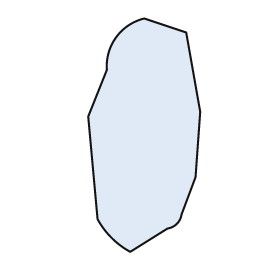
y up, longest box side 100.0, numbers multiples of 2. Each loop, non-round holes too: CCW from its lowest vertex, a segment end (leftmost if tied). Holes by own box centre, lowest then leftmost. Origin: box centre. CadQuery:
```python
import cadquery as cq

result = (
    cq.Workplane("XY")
    .moveTo(-6.0, -50.0)
    .lineTo(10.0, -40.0)
    .threePointArc((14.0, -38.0), (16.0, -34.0))
    .lineTo(22.0, -18.0)
    .lineTo(24.0, 10.0)
    .lineTo(18.0, 44.0)
    .lineTo(0.0, 50.0)
    .threePointArc((-12.0, 42.0), (-16.0, 28.0))
    .lineTo(-24.0, 8.0)
    .lineTo(-20.0, -36.0)
    .threePointArc((-14.0, -44.0), (-6.0, -50.0))
    .close()
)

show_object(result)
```